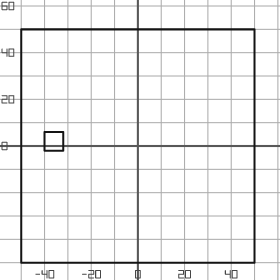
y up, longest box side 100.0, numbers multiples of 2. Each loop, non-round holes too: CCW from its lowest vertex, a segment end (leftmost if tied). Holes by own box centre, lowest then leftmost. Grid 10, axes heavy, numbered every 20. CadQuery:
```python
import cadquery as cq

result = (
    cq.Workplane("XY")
    .moveTo(-50.0, -50.0)
    .lineTo(50.0, -50.0)
    .lineTo(50.0, 50.0)
    .lineTo(-50.0, 50.0)
    .close()
    .moveTo(-40.0, -2.0)
    .lineTo(-32.0, -2.0)
    .lineTo(-32.0, 6.0)
    .lineTo(-40.0, 6.0)
    .close()
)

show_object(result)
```